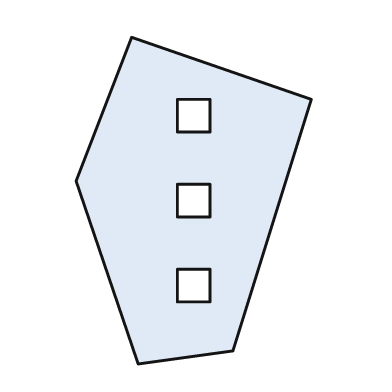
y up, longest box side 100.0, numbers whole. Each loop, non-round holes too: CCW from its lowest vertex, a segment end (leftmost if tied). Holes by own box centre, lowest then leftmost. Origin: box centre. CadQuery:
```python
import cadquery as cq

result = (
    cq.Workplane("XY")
    .moveTo(-17.0, -50.0)
    .lineTo(12.0, -46.0)
    .lineTo(36.0, 31.0)
    .lineTo(-19.0, 50.0)
    .lineTo(-36.0, 6.0)
    .close()
    .moveTo(-5.0, -31.0)
    .lineTo(5.0, -31.0)
    .lineTo(5.0, -21.0)
    .lineTo(-5.0, -21.0)
    .close()
    .moveTo(-5.0, -5.0)
    .lineTo(5.0, -5.0)
    .lineTo(5.0, 5.0)
    .lineTo(-5.0, 5.0)
    .close()
    .moveTo(-5.0, 21.0)
    .lineTo(5.0, 21.0)
    .lineTo(5.0, 31.0)
    .lineTo(-5.0, 31.0)
    .close()
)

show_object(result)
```